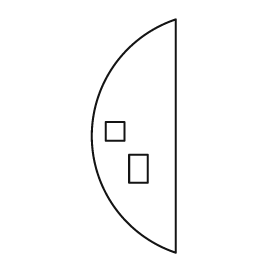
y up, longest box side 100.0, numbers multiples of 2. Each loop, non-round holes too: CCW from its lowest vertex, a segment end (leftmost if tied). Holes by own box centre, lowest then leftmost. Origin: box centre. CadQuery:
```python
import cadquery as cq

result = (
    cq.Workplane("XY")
    .moveTo(18.0, -50.0)
    .lineTo(18.0, 50.0)
    .threePointArc((-18.0, 0.0), (18.0, -50.0))
    .close()
    .moveTo(-2.0, -20.0)
    .lineTo(6.0, -20.0)
    .lineTo(6.0, -8.0)
    .lineTo(-2.0, -8.0)
    .close()
    .moveTo(-12.0, -2.0)
    .lineTo(-4.0, -2.0)
    .lineTo(-4.0, 6.0)
    .lineTo(-12.0, 6.0)
    .close()
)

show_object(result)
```